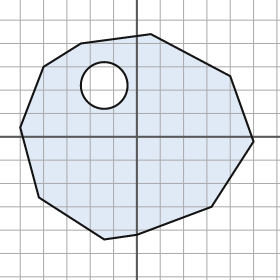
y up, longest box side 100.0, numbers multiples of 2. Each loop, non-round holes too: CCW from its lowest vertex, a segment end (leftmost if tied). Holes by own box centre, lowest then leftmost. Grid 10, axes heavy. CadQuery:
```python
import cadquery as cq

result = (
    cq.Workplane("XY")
    .moveTo(-14.0, -44.0)
    .lineTo(0.0, -42.0)
    .lineTo(32.0, -30.0)
    .lineTo(50.0, -2.0)
    .lineTo(40.0, 26.0)
    .lineTo(6.0, 44.0)
    .lineTo(-24.0, 40.0)
    .lineTo(-40.0, 30.0)
    .lineTo(-50.0, 4.0)
    .lineTo(-42.0, -26.0)
    .close()
    .moveTo(-14.0, 22.0)
    .circle(10.0)
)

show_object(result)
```